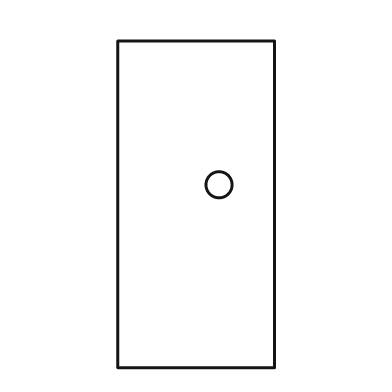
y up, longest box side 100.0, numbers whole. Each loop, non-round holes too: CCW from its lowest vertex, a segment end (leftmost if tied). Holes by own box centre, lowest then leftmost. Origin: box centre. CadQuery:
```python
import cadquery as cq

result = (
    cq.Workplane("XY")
    .moveTo(-24.0, -50.0)
    .lineTo(24.0, -50.0)
    .lineTo(24.0, 50.0)
    .lineTo(-24.0, 50.0)
    .close()
    .moveTo(7.0, 6.0)
    .circle(4.0)
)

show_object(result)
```